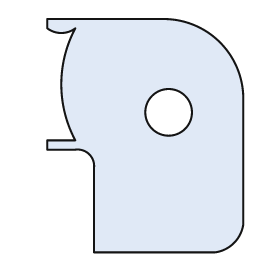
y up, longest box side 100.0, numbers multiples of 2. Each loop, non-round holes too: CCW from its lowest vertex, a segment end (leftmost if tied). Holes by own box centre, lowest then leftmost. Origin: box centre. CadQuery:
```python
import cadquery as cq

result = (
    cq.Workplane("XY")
    .moveTo(-22.0, -50.0)
    .lineTo(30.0, -50.0)
    .threePointArc((38.0, -46.0), (42.0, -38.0))
    .lineTo(42.0, 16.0)
    .threePointArc((32.0, 40.0), (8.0, 50.0))
    .lineTo(-42.0, 50.0)
    .lineTo(-42.0, 46.0)
    .threePointArc((-36.0, 44.0), (-30.0, 46.0))
    .threePointArc((-36.0, 22.0), (-30.0, -2.0))
    .lineTo(-42.0, -2.0)
    .lineTo(-42.0, -6.0)
    .lineTo(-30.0, -6.0)
    .threePointArc((-24.0, -8.0), (-22.0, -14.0))
    .close()
    .moveTo(10.0, 10.0)
    .circle(10.0)
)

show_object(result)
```